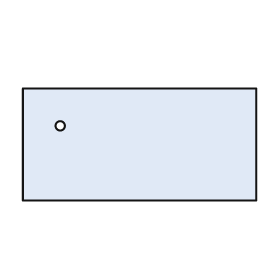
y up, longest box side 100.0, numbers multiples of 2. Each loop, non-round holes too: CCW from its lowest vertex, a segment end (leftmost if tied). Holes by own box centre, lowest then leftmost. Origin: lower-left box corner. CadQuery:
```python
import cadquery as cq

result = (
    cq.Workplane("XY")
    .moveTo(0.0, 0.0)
    .lineTo(100.0, 0.0)
    .lineTo(100.0, 48.0)
    .lineTo(0.0, 48.0)
    .close()
    .moveTo(16.0, 32.0)
    .circle(2.0)
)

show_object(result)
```